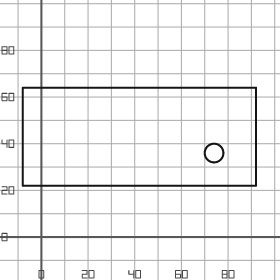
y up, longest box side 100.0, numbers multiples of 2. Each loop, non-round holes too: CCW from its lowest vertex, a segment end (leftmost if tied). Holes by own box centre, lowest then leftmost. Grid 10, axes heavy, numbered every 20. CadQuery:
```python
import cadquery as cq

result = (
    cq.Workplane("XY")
    .moveTo(-8.0, 22.0)
    .lineTo(92.0, 22.0)
    .lineTo(92.0, 64.0)
    .lineTo(-8.0, 64.0)
    .close()
    .moveTo(74.0, 36.0)
    .circle(4.0)
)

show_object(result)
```